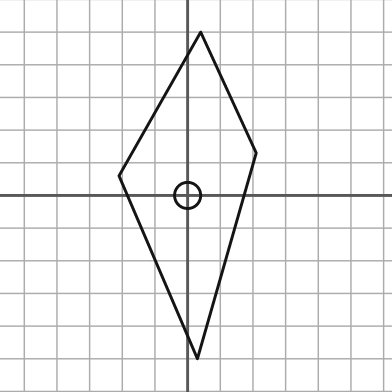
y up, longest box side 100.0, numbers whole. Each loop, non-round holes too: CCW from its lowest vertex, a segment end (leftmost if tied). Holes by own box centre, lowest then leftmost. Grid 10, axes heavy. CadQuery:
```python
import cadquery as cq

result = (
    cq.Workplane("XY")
    .moveTo(3.0, -50.0)
    .lineTo(21.0, 13.0)
    .lineTo(4.0, 50.0)
    .lineTo(-21.0, 6.0)
    .close()
    .moveTo(0.0, 0.0)
    .circle(4.0)
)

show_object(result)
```